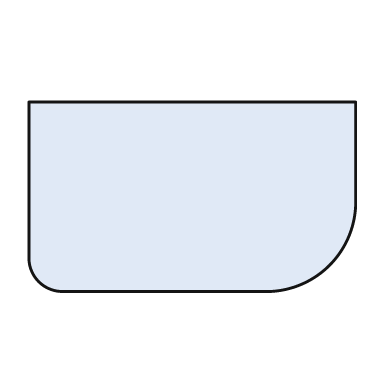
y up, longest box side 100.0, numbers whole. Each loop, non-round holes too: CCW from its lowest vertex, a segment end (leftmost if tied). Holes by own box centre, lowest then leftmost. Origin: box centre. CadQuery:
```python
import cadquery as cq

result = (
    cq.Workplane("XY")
    .moveTo(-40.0, -29.0)
    .lineTo(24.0, -29.0)
    .threePointArc((42.0, -21.0), (50.0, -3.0))
    .lineTo(50.0, 29.0)
    .lineTo(-50.0, 29.0)
    .lineTo(-50.0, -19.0)
    .threePointArc((-47.0, -26.0), (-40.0, -29.0))
    .close()
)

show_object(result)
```